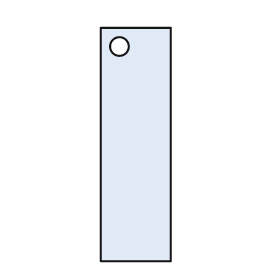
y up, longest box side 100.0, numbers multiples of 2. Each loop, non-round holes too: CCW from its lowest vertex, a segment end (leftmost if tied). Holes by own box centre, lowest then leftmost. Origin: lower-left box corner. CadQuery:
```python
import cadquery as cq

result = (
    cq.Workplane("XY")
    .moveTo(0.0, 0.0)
    .lineTo(30.0, 0.0)
    .lineTo(30.0, 100.0)
    .lineTo(0.0, 100.0)
    .close()
    .moveTo(8.0, 92.0)
    .circle(4.0)
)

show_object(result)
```